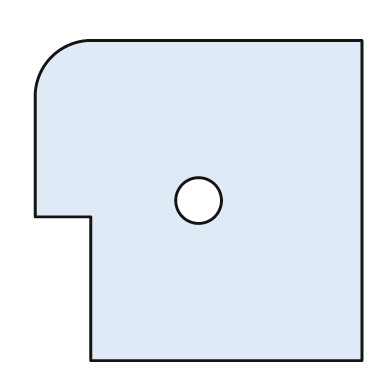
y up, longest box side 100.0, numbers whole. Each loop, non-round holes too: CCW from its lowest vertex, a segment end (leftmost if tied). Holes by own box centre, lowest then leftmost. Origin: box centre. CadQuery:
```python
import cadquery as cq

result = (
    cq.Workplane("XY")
    .moveTo(-33.0, -49.0)
    .lineTo(50.0, -49.0)
    .lineTo(50.0, 49.0)
    .lineTo(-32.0, 49.0)
    .threePointArc((-45.0, 44.0), (-50.0, 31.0))
    .lineTo(-50.0, -5.0)
    .lineTo(-33.0, -5.0)
    .close()
    .moveTo(0.0, 0.0)
    .circle(7.0)
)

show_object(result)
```